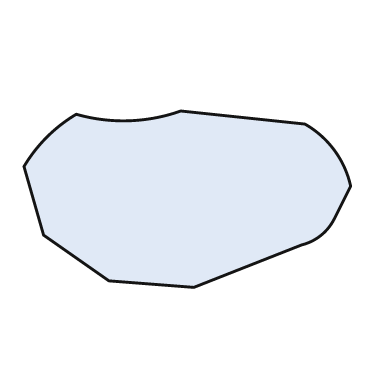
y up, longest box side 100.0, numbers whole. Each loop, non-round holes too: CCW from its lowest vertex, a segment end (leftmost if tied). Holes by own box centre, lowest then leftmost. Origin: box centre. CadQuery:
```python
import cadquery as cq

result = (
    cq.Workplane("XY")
    .moveTo(2.0, -27.0)
    .lineTo(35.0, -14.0)
    .threePointArc((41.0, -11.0), (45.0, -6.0))
    .lineTo(50.0, 4.0)
    .threePointArc((45.0, 15.0), (36.0, 23.0))
    .lineTo(-2.0, 27.0)
    .threePointArc((-18.0, 24.0), (-34.0, 26.0))
    .threePointArc((-43.0, 19.0), (-50.0, 10.0))
    .lineTo(-44.0, -11.0)
    .lineTo(-24.0, -25.0)
    .close()
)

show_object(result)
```